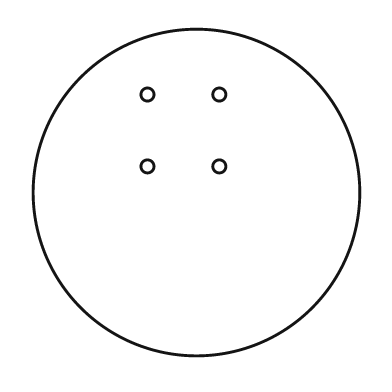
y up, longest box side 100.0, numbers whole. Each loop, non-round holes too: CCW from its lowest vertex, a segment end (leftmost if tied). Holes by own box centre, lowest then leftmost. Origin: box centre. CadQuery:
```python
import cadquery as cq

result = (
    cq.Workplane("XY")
    .moveTo(0.0, 0.0)
    .circle(50.0)
    .moveTo(-15.0, 8.0)
    .circle(2.0)
    .moveTo(7.0, 8.0)
    .circle(2.0)
    .moveTo(-15.0, 30.0)
    .circle(2.0)
    .moveTo(7.0, 30.0)
    .circle(2.0)
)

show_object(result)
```